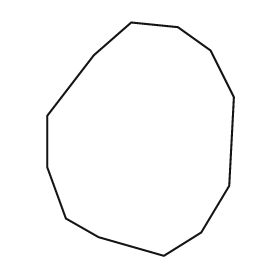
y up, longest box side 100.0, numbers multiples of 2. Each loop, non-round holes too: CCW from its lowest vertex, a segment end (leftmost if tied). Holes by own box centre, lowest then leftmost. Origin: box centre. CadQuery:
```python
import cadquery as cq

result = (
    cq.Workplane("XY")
    .moveTo(10.0, -50.0)
    .lineTo(26.0, -40.0)
    .lineTo(38.0, -20.0)
    .lineTo(40.0, 18.0)
    .lineTo(30.0, 38.0)
    .lineTo(16.0, 48.0)
    .lineTo(-4.0, 50.0)
    .lineTo(-20.0, 36.0)
    .lineTo(-40.0, 10.0)
    .lineTo(-40.0, -12.0)
    .lineTo(-32.0, -34.0)
    .lineTo(-18.0, -42.0)
    .close()
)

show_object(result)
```